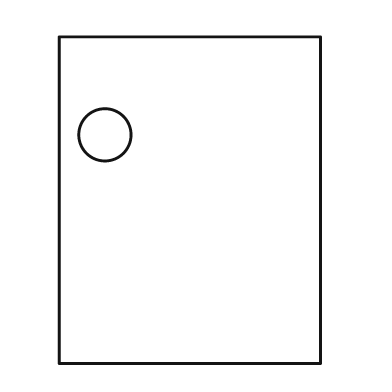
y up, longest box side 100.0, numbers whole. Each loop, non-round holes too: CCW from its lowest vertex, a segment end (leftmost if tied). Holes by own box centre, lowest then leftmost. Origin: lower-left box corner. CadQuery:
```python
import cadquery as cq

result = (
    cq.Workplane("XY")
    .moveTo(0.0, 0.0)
    .lineTo(80.0, 0.0)
    .lineTo(80.0, 100.0)
    .lineTo(0.0, 100.0)
    .close()
    .moveTo(14.0, 70.0)
    .circle(8.0)
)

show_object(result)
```